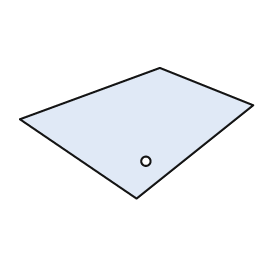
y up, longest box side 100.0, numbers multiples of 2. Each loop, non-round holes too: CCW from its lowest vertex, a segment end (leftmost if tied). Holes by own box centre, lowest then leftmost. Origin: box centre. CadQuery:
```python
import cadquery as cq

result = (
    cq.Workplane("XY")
    .moveTo(0.0, -28.0)
    .lineTo(50.0, 12.0)
    .lineTo(10.0, 28.0)
    .lineTo(-50.0, 6.0)
    .close()
    .moveTo(4.0, -12.0)
    .circle(2.0)
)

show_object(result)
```